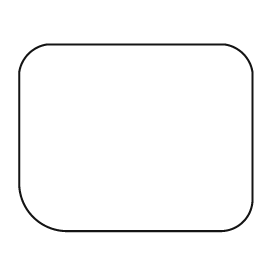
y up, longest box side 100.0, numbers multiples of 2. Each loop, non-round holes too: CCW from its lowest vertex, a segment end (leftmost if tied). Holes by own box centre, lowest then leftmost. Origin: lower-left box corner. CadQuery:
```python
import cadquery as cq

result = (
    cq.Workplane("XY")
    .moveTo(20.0, 0.0)
    .lineTo(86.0, 0.0)
    .threePointArc((96.0, 4.0), (100.0, 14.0))
    .lineTo(100.0, 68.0)
    .threePointArc((96.0, 76.0), (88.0, 80.0))
    .lineTo(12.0, 80.0)
    .threePointArc((4.0, 76.0), (0.0, 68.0))
    .lineTo(0.0, 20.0)
    .threePointArc((6.0, 6.0), (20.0, 0.0))
    .close()
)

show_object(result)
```